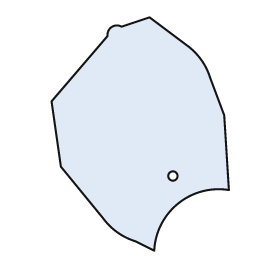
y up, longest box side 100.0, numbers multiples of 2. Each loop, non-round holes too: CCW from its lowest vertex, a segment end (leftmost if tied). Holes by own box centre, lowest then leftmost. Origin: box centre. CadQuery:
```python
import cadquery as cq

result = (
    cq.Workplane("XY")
    .moveTo(6.0, -50.0)
    .threePointArc((16.0, -30.0), (38.0, -24.0))
    .lineTo(36.0, 8.0)
    .lineTo(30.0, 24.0)
    .threePointArc((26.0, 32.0), (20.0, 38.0))
    .lineTo(4.0, 50.0)
    .lineTo(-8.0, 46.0)
    .threePointArc((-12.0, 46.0), (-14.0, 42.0))
    .lineTo(-38.0, 14.0)
    .lineTo(-34.0, -14.0)
    .lineTo(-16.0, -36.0)
    .threePointArc((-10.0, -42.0), (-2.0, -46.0))
    .close()
    .moveTo(14.0, -18.0)
    .circle(2.0)
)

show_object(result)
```